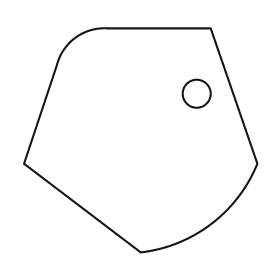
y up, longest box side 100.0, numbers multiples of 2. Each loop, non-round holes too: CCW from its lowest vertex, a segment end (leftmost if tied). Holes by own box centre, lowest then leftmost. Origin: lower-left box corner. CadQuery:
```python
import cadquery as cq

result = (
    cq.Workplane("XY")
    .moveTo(50.0, 0.0)
    .threePointArc((80.0, 12.0), (100.0, 38.0))
    .lineTo(80.0, 96.0)
    .lineTo(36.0, 96.0)
    .threePointArc((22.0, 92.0), (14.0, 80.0))
    .lineTo(0.0, 38.0)
    .close()
    .moveTo(74.0, 68.0)
    .circle(6.0)
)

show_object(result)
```